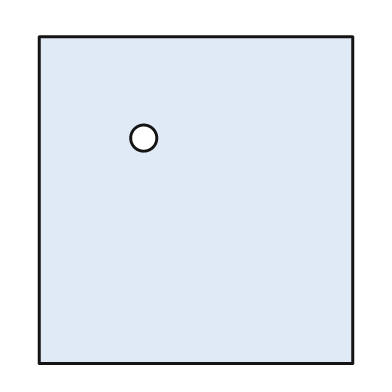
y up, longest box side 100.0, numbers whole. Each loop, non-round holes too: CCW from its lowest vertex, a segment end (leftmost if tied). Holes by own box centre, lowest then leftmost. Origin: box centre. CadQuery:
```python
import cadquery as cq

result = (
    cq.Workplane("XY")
    .moveTo(-48.0, -50.0)
    .lineTo(48.0, -50.0)
    .lineTo(48.0, 50.0)
    .lineTo(-48.0, 50.0)
    .close()
    .moveTo(-16.0, 19.0)
    .circle(4.0)
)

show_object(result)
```